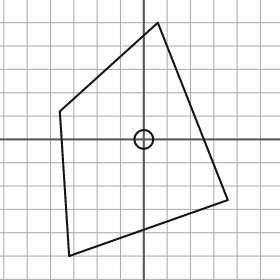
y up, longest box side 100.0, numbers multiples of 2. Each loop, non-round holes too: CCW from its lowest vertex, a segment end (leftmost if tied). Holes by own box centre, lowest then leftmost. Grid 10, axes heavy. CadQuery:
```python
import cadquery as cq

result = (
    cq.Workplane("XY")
    .moveTo(-32.0, -50.0)
    .lineTo(36.0, -26.0)
    .lineTo(6.0, 50.0)
    .lineTo(-36.0, 12.0)
    .close()
    .moveTo(0.0, 0.0)
    .circle(4.0)
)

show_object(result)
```